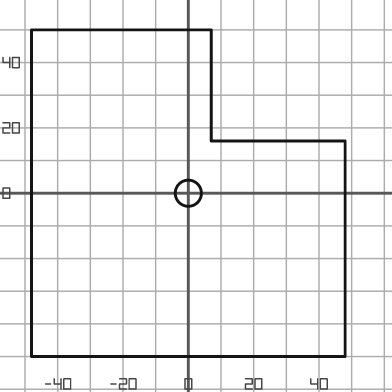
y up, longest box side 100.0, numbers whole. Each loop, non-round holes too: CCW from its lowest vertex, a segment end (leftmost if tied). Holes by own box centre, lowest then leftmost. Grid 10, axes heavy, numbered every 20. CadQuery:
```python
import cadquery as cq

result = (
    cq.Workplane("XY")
    .moveTo(-48.0, -50.0)
    .lineTo(48.0, -50.0)
    .lineTo(48.0, 16.0)
    .lineTo(7.0, 16.0)
    .lineTo(7.0, 50.0)
    .lineTo(-48.0, 50.0)
    .close()
    .moveTo(0.0, 0.0)
    .circle(4.0)
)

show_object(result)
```